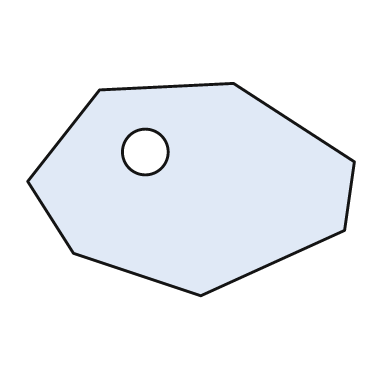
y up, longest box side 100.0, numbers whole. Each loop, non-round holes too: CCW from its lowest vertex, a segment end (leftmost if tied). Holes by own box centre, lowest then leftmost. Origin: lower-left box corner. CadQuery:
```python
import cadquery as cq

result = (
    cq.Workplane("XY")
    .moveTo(53.0, 0.0)
    .lineTo(97.0, 20.0)
    .lineTo(100.0, 41.0)
    .lineTo(63.0, 65.0)
    .lineTo(22.0, 63.0)
    .lineTo(0.0, 35.0)
    .lineTo(14.0, 13.0)
    .close()
    .moveTo(36.0, 44.0)
    .circle(7.0)
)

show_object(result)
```